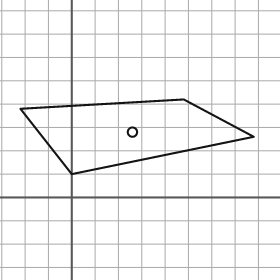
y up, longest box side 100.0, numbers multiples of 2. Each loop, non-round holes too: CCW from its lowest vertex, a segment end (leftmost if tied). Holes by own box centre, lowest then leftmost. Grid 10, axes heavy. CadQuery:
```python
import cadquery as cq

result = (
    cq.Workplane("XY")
    .moveTo(0.0, 10.0)
    .lineTo(78.0, 26.0)
    .lineTo(48.0, 42.0)
    .lineTo(-22.0, 38.0)
    .close()
    .moveTo(26.0, 28.0)
    .circle(2.0)
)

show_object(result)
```